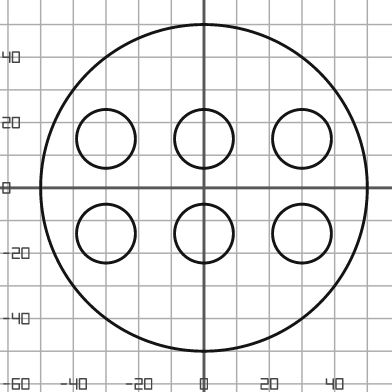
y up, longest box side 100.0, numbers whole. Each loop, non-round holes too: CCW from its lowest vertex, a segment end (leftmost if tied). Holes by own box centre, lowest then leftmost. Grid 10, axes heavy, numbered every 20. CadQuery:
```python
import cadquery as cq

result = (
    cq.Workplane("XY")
    .moveTo(0.0, 0.0)
    .circle(50.0)
    .moveTo(-30.0, -14.0)
    .circle(9.0)
    .moveTo(0.0, -14.0)
    .circle(9.0)
    .moveTo(30.0, -14.0)
    .circle(9.0)
    .moveTo(-30.0, 15.0)
    .circle(9.0)
    .moveTo(0.0, 15.0)
    .circle(9.0)
    .moveTo(30.0, 15.0)
    .circle(9.0)
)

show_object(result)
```